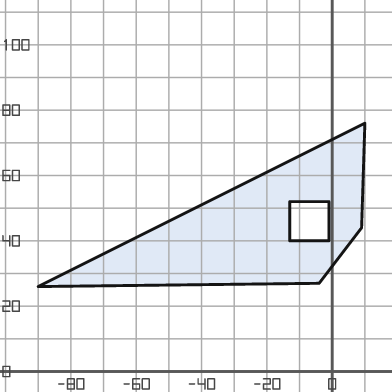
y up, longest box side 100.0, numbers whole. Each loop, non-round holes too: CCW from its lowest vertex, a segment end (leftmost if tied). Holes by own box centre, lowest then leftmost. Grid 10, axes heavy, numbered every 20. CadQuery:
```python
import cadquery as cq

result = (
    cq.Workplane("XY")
    .moveTo(-90.0, 26.0)
    .lineTo(-4.0, 27.0)
    .lineTo(9.0, 44.0)
    .lineTo(10.0, 76.0)
    .close()
    .moveTo(-13.0, 40.0)
    .lineTo(-1.0, 40.0)
    .lineTo(-1.0, 52.0)
    .lineTo(-13.0, 52.0)
    .close()
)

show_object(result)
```